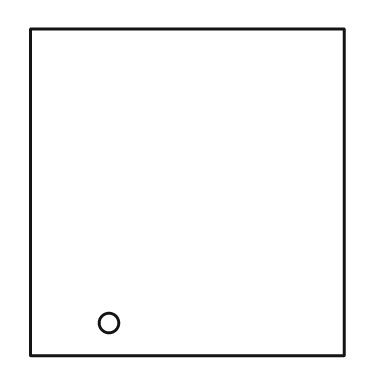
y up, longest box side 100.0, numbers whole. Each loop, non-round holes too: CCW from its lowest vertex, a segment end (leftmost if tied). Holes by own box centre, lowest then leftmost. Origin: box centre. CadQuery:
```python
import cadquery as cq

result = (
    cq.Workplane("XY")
    .moveTo(-48.0, -50.0)
    .lineTo(48.0, -50.0)
    .lineTo(48.0, 50.0)
    .lineTo(-48.0, 50.0)
    .close()
    .moveTo(-24.0, -40.0)
    .circle(3.0)
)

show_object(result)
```